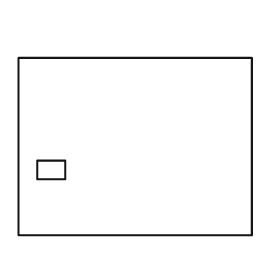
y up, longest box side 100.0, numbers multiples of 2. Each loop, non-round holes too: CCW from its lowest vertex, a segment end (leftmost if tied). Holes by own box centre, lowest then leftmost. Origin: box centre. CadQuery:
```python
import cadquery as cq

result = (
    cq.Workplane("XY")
    .moveTo(-50.0, -38.0)
    .lineTo(50.0, -38.0)
    .lineTo(50.0, 38.0)
    .lineTo(-50.0, 38.0)
    .close()
    .moveTo(-42.0, -14.0)
    .lineTo(-30.0, -14.0)
    .lineTo(-30.0, -6.0)
    .lineTo(-42.0, -6.0)
    .close()
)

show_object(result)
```